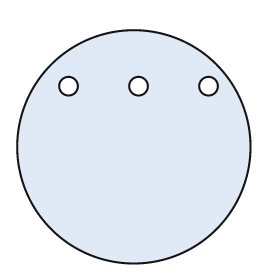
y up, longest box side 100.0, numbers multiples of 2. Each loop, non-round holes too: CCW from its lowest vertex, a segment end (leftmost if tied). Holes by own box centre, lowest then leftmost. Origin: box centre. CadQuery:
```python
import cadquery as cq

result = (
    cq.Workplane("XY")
    .moveTo(0.0, 0.0)
    .circle(50.0)
    .moveTo(-28.0, 26.0)
    .circle(4.0)
    .moveTo(2.0, 26.0)
    .circle(4.0)
    .moveTo(32.0, 26.0)
    .circle(4.0)
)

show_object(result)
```